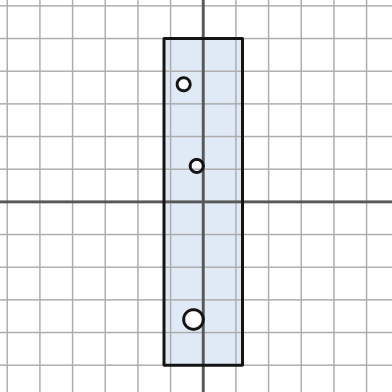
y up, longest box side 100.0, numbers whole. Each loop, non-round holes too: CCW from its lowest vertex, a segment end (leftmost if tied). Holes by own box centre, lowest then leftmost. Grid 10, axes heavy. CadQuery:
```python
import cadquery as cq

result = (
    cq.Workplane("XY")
    .moveTo(-12.0, -50.0)
    .lineTo(12.0, -50.0)
    .lineTo(12.0, 50.0)
    .lineTo(-12.0, 50.0)
    .close()
    .moveTo(-3.0, -36.0)
    .circle(3.0)
    .moveTo(-2.0, 11.0)
    .circle(2.0)
    .moveTo(-6.0, 36.0)
    .circle(2.0)
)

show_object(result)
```